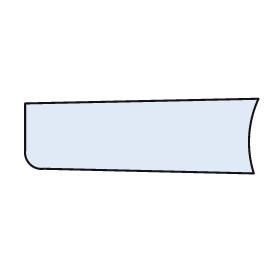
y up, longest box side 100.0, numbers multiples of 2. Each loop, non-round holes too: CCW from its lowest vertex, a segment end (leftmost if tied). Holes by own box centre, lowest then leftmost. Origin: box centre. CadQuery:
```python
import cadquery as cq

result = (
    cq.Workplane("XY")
    .moveTo(48.0, -16.0)
    .threePointArc((46.0, 0.0), (50.0, 16.0))
    .lineTo(-50.0, 14.0)
    .lineTo(-50.0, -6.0)
    .threePointArc((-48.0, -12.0), (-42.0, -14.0))
    .close()
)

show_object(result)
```